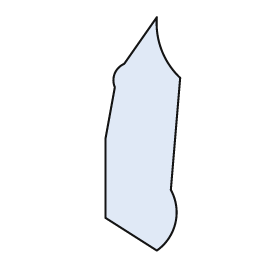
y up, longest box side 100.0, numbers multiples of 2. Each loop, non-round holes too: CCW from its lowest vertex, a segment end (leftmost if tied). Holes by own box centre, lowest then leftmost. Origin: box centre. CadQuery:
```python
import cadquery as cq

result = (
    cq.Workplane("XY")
    .moveTo(6.0, -50.0)
    .threePointArc((14.0, -38.0), (12.0, -24.0))
    .lineTo(16.0, 24.0)
    .threePointArc((8.0, 36.0), (6.0, 50.0))
    .lineTo(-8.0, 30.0)
    .threePointArc((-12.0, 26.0), (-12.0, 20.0))
    .lineTo(-16.0, -2.0)
    .lineTo(-16.0, -36.0)
    .close()
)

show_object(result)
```